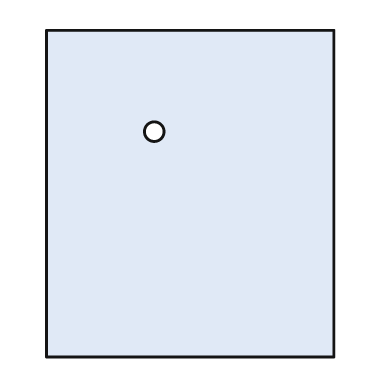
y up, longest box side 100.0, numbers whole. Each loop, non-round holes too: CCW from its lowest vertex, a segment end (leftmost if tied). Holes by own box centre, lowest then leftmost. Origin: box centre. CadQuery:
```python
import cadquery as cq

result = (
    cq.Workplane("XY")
    .moveTo(-44.0, -50.0)
    .lineTo(44.0, -50.0)
    .lineTo(44.0, 50.0)
    .lineTo(-44.0, 50.0)
    .close()
    .moveTo(-11.0, 19.0)
    .circle(3.0)
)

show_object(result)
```